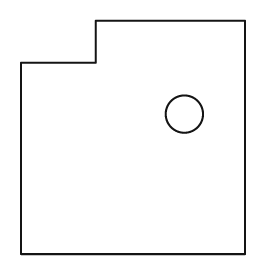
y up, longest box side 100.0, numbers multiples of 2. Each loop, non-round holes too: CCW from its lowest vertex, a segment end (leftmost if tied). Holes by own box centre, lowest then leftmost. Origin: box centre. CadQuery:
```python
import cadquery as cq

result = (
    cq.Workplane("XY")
    .moveTo(-48.0, -50.0)
    .lineTo(48.0, -50.0)
    .lineTo(48.0, 50.0)
    .lineTo(-16.0, 50.0)
    .lineTo(-16.0, 32.0)
    .lineTo(-48.0, 32.0)
    .close()
    .moveTo(22.0, 10.0)
    .circle(8.0)
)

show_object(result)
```